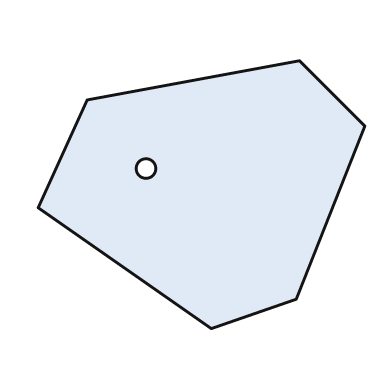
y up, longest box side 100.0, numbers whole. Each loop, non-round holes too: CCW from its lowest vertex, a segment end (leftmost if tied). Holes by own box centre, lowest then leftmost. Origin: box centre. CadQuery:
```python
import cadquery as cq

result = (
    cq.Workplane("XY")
    .moveTo(3.0, -41.0)
    .lineTo(29.0, -32.0)
    .lineTo(50.0, 21.0)
    .lineTo(30.0, 41.0)
    .lineTo(-35.0, 29.0)
    .lineTo(-50.0, -4.0)
    .close()
    .moveTo(-17.0, 8.0)
    .circle(3.0)
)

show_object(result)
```